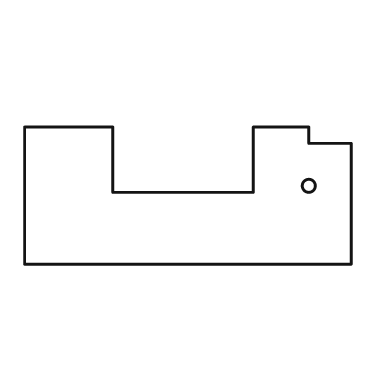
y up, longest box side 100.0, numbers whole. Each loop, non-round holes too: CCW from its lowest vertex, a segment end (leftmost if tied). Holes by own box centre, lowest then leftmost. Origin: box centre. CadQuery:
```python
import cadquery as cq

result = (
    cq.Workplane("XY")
    .moveTo(-50.0, -21.0)
    .lineTo(50.0, -21.0)
    .lineTo(50.0, 16.0)
    .lineTo(37.0, 16.0)
    .lineTo(37.0, 21.0)
    .lineTo(20.0, 21.0)
    .lineTo(20.0, 1.0)
    .lineTo(-23.0, 1.0)
    .lineTo(-23.0, 21.0)
    .lineTo(-50.0, 21.0)
    .close()
    .moveTo(37.0, 3.0)
    .circle(2.0)
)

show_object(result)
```